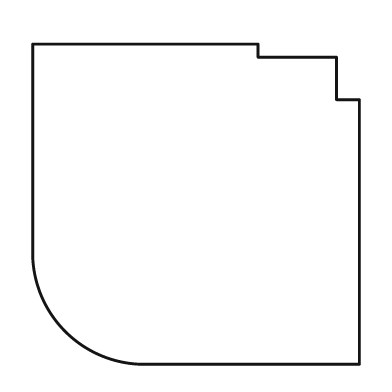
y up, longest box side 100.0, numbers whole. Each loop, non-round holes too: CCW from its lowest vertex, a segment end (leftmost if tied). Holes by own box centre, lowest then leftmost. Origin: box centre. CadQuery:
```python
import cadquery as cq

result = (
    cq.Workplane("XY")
    .moveTo(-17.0, -49.0)
    .lineTo(50.0, -49.0)
    .lineTo(50.0, 32.0)
    .lineTo(43.0, 32.0)
    .lineTo(43.0, 45.0)
    .lineTo(19.0, 45.0)
    .lineTo(19.0, 49.0)
    .lineTo(-50.0, 49.0)
    .lineTo(-50.0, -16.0)
    .threePointArc((-40.0, -39.0), (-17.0, -49.0))
    .close()
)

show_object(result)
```